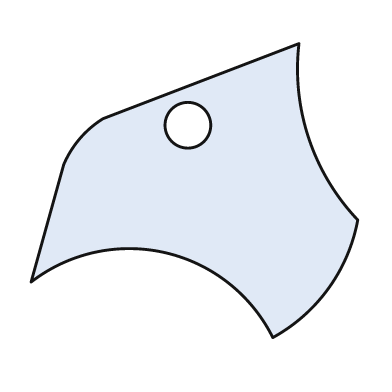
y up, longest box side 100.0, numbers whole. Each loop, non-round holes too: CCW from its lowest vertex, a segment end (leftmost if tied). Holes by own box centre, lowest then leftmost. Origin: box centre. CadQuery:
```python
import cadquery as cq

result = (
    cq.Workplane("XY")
    .moveTo(24.0, -45.0)
    .threePointArc((41.0, -30.0), (50.0, -9.0))
    .threePointArc((35.0, 16.0), (32.0, 45.0))
    .lineTo(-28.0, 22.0)
    .threePointArc((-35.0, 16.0), (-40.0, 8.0))
    .lineTo(-50.0, -28.0)
    .threePointArc((-9.0, -19.0), (24.0, -45.0))
    .close()
    .moveTo(-2.0, 20.0)
    .circle(7.0)
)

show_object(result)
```